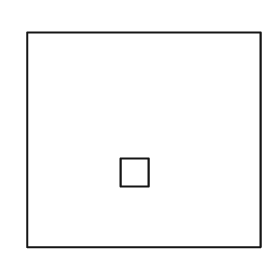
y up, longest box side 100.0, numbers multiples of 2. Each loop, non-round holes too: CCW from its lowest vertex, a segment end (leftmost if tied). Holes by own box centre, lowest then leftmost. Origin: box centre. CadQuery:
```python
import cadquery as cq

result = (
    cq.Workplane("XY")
    .moveTo(-50.0, -46.0)
    .lineTo(50.0, -46.0)
    .lineTo(50.0, 46.0)
    .lineTo(-50.0, 46.0)
    .close()
    .moveTo(-10.0, -20.0)
    .lineTo(2.0, -20.0)
    .lineTo(2.0, -8.0)
    .lineTo(-10.0, -8.0)
    .close()
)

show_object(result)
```